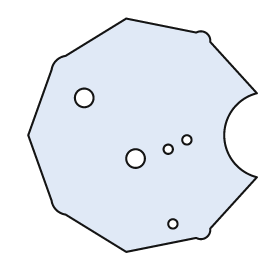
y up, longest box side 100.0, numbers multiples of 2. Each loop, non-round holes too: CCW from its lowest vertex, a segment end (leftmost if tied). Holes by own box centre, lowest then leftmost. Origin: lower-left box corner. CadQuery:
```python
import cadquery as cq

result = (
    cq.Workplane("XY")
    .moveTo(42.0, 0.0)
    .lineTo(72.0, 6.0)
    .threePointArc((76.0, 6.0), (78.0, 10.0))
    .lineTo(98.0, 32.0)
    .threePointArc((84.0, 50.0), (98.0, 68.0))
    .lineTo(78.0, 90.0)
    .threePointArc((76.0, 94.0), (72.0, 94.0))
    .lineTo(42.0, 100.0)
    .lineTo(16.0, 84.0)
    .threePointArc((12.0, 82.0), (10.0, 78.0))
    .lineTo(0.0, 50.0)
    .lineTo(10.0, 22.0)
    .threePointArc((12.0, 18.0), (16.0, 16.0))
    .close()
    .moveTo(62.0, 12.0)
    .circle(2.0)
    .moveTo(46.0, 40.0)
    .circle(4.0)
    .moveTo(60.0, 44.0)
    .circle(2.0)
    .moveTo(68.0, 48.0)
    .circle(2.0)
    .moveTo(24.0, 66.0)
    .circle(4.0)
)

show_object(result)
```